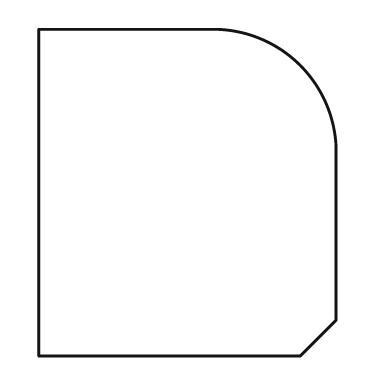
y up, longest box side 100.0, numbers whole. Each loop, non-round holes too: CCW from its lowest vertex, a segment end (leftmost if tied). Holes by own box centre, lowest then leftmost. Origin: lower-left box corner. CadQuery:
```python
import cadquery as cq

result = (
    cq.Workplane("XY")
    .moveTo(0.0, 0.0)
    .lineTo(80.0, 0.0)
    .lineTo(91.0, 11.0)
    .lineTo(91.0, 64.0)
    .threePointArc((80.0, 89.0), (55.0, 100.0))
    .lineTo(0.0, 100.0)
    .close()
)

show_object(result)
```